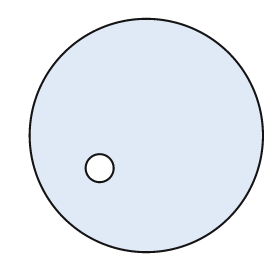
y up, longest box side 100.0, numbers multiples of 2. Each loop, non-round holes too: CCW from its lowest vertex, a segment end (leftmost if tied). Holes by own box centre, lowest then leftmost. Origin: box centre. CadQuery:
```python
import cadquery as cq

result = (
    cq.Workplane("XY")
    .moveTo(0.0, 0.0)
    .circle(50.0)
    .moveTo(-20.0, -14.0)
    .circle(6.0)
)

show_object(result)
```